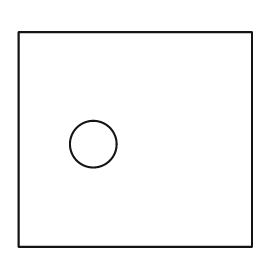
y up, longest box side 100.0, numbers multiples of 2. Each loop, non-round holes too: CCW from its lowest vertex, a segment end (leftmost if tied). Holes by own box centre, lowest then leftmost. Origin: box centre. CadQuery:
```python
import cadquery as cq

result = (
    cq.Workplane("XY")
    .moveTo(-50.0, -46.0)
    .lineTo(50.0, -46.0)
    .lineTo(50.0, 46.0)
    .lineTo(-50.0, 46.0)
    .close()
    .moveTo(-18.0, -2.0)
    .circle(10.0)
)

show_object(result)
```